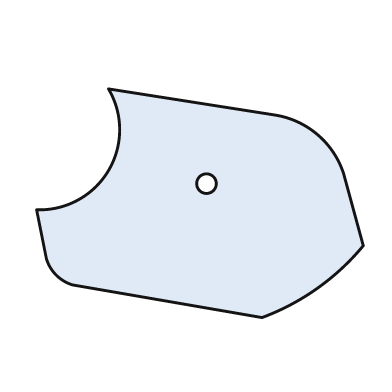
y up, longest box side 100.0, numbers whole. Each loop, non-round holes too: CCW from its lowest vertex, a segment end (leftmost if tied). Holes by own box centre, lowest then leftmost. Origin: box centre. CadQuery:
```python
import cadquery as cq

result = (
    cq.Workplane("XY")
    .moveTo(19.0, -35.0)
    .threePointArc((36.0, -26.0), (50.0, -13.0))
    .lineTo(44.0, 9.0)
    .threePointArc((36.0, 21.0), (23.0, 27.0))
    .lineTo(-28.0, 35.0)
    .threePointArc((-28.0, 10.0), (-50.0, -2.0))
    .lineTo(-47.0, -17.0)
    .threePointArc((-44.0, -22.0), (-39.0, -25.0))
    .close()
    .moveTo(2.0, 6.0)
    .circle(3.0)
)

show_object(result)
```